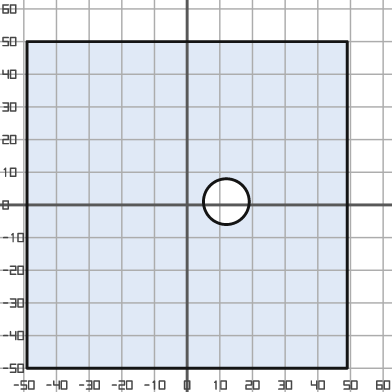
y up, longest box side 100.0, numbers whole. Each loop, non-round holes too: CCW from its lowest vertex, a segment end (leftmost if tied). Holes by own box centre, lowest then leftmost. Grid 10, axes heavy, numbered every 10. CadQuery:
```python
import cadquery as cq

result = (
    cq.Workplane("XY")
    .moveTo(-49.0, -50.0)
    .lineTo(49.0, -50.0)
    .lineTo(49.0, 50.0)
    .lineTo(-49.0, 50.0)
    .close()
    .moveTo(12.0, 1.0)
    .circle(7.0)
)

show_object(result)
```